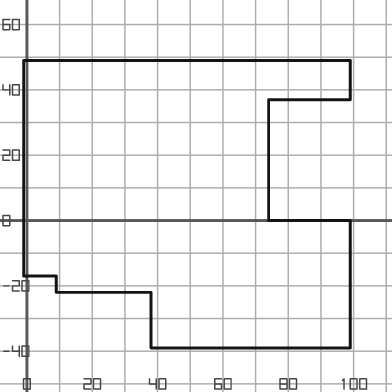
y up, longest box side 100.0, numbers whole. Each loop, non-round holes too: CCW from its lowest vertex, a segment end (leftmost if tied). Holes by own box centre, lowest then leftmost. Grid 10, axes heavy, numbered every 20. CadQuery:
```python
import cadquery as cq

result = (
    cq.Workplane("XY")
    .moveTo(38.0, -39.0)
    .lineTo(99.0, -39.0)
    .lineTo(99.0, 0.0)
    .lineTo(74.0, 0.0)
    .lineTo(74.0, 37.0)
    .lineTo(99.0, 37.0)
    .lineTo(99.0, 49.0)
    .lineTo(-1.0, 49.0)
    .lineTo(-1.0, -17.0)
    .lineTo(9.0, -17.0)
    .lineTo(9.0, -22.0)
    .lineTo(38.0, -22.0)
    .close()
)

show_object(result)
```